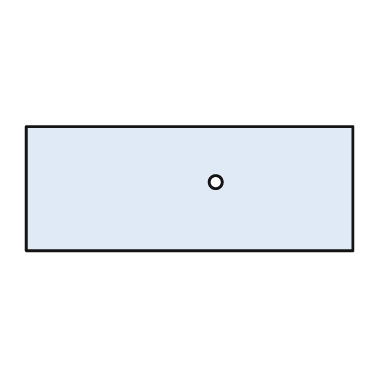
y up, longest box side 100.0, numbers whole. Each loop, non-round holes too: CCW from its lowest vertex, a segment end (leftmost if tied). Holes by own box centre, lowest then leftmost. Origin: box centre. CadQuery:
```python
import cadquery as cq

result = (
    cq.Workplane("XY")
    .moveTo(-50.0, -19.0)
    .lineTo(50.0, -19.0)
    .lineTo(50.0, 19.0)
    .lineTo(-50.0, 19.0)
    .close()
    .moveTo(8.0, 2.0)
    .circle(2.0)
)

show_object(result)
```